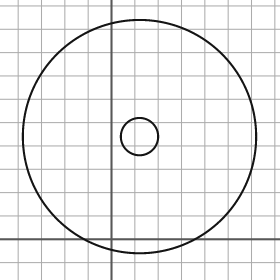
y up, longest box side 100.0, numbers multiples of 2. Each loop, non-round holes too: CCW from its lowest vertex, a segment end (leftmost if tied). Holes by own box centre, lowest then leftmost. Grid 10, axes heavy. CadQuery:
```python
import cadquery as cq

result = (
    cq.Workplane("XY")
    .moveTo(12.0, 44.0)
    .circle(50.0)
    .moveTo(12.0, 44.0)
    .circle(8.0)
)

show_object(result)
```